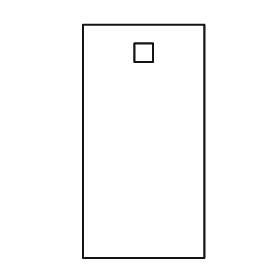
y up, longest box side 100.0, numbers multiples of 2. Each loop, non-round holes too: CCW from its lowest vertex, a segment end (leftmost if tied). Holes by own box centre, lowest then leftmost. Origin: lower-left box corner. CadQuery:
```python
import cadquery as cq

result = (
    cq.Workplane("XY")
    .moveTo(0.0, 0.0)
    .lineTo(52.0, 0.0)
    .lineTo(52.0, 100.0)
    .lineTo(0.0, 100.0)
    .close()
    .moveTo(22.0, 84.0)
    .lineTo(30.0, 84.0)
    .lineTo(30.0, 92.0)
    .lineTo(22.0, 92.0)
    .close()
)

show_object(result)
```